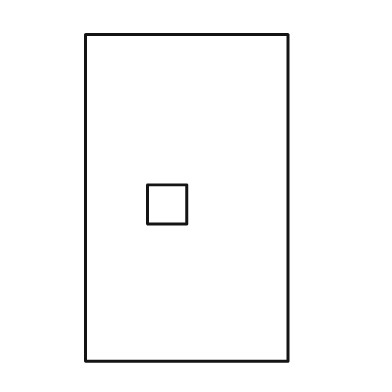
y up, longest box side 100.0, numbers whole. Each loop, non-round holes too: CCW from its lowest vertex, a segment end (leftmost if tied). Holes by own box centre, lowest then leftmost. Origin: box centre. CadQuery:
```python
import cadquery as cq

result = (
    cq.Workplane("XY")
    .moveTo(-31.0, -50.0)
    .lineTo(31.0, -50.0)
    .lineTo(31.0, 50.0)
    .lineTo(-31.0, 50.0)
    .close()
    .moveTo(-12.0, -8.0)
    .lineTo(0.0, -8.0)
    .lineTo(0.0, 4.0)
    .lineTo(-12.0, 4.0)
    .close()
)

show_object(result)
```